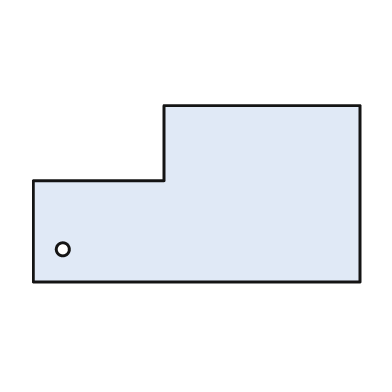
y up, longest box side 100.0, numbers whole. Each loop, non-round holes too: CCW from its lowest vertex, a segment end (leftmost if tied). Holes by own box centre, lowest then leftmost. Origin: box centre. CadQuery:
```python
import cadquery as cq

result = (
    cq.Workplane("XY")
    .moveTo(-50.0, -27.0)
    .lineTo(50.0, -27.0)
    .lineTo(50.0, 27.0)
    .lineTo(-10.0, 27.0)
    .lineTo(-10.0, 4.0)
    .lineTo(-50.0, 4.0)
    .close()
    .moveTo(-41.0, -17.0)
    .circle(2.0)
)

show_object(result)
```